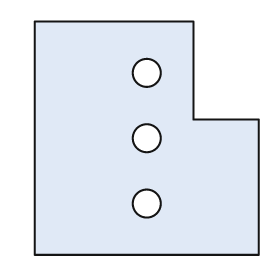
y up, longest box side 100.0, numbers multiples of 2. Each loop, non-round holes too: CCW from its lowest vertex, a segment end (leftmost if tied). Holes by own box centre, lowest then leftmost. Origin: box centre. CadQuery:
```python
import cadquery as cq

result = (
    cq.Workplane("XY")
    .moveTo(-48.0, -50.0)
    .lineTo(48.0, -50.0)
    .lineTo(48.0, 8.0)
    .lineTo(20.0, 8.0)
    .lineTo(20.0, 50.0)
    .lineTo(-48.0, 50.0)
    .close()
    .moveTo(0.0, -28.0)
    .circle(6.0)
    .moveTo(0.0, 0.0)
    .circle(6.0)
    .moveTo(0.0, 28.0)
    .circle(6.0)
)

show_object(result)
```